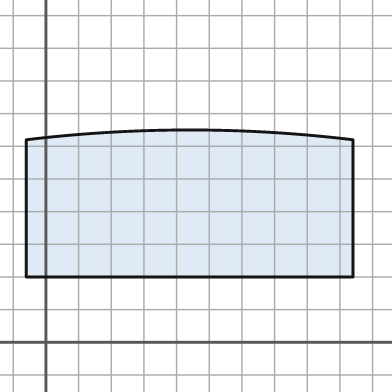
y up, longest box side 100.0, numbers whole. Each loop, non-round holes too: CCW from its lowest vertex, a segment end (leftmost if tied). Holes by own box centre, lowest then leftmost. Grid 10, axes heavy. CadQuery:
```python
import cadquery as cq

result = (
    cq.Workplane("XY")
    .moveTo(-6.0, 20.0)
    .lineTo(94.0, 20.0)
    .lineTo(94.0, 62.0)
    .threePointArc((44.0, 65.0), (-6.0, 62.0))
    .close()
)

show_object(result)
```